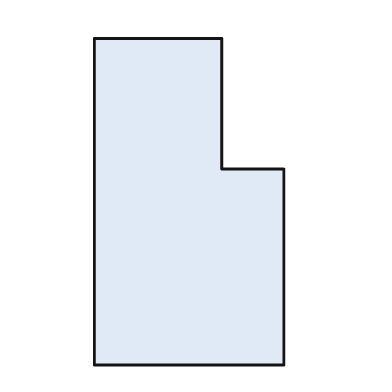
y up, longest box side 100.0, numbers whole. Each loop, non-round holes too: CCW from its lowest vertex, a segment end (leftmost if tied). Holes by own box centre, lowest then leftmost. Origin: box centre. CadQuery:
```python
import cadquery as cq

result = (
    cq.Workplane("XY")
    .moveTo(-29.0, -50.0)
    .lineTo(29.0, -50.0)
    .lineTo(29.0, 10.0)
    .lineTo(10.0, 10.0)
    .lineTo(10.0, 50.0)
    .lineTo(-29.0, 50.0)
    .close()
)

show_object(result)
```